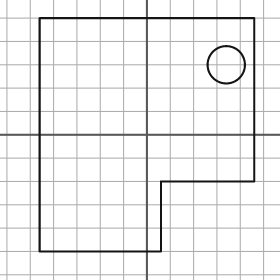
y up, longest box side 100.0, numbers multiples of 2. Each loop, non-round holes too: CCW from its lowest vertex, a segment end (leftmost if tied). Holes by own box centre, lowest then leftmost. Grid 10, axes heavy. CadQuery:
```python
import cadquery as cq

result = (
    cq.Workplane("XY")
    .moveTo(-46.0, -50.0)
    .lineTo(6.0, -50.0)
    .lineTo(6.0, -20.0)
    .lineTo(46.0, -20.0)
    .lineTo(46.0, 50.0)
    .lineTo(-46.0, 50.0)
    .close()
    .moveTo(34.0, 30.0)
    .circle(8.0)
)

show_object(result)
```